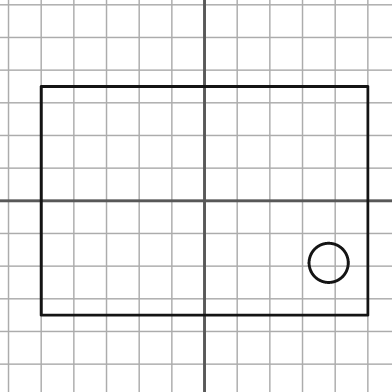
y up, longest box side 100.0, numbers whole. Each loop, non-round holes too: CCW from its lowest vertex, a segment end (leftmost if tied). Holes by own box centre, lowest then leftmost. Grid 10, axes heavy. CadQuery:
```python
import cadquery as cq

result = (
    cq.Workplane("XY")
    .moveTo(-50.0, -35.0)
    .lineTo(50.0, -35.0)
    .lineTo(50.0, 35.0)
    .lineTo(-50.0, 35.0)
    .close()
    .moveTo(38.0, -19.0)
    .circle(6.0)
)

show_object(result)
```